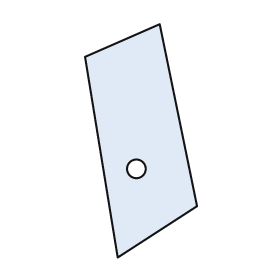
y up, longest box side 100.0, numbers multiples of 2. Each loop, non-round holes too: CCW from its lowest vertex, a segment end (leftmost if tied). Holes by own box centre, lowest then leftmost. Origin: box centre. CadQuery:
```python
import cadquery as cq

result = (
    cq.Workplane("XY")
    .moveTo(-10.0, -50.0)
    .lineTo(24.0, -28.0)
    .lineTo(8.0, 50.0)
    .lineTo(-24.0, 36.0)
    .close()
    .moveTo(-2.0, -12.0)
    .circle(4.0)
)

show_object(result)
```